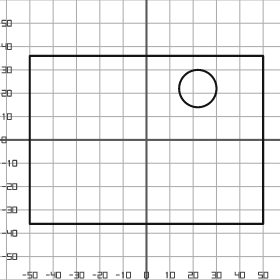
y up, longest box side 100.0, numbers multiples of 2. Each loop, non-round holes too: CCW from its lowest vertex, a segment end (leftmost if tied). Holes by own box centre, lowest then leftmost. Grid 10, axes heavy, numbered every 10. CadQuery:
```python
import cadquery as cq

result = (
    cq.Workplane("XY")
    .moveTo(-50.0, -36.0)
    .lineTo(50.0, -36.0)
    .lineTo(50.0, 36.0)
    .lineTo(-50.0, 36.0)
    .close()
    .moveTo(22.0, 22.0)
    .circle(8.0)
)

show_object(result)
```